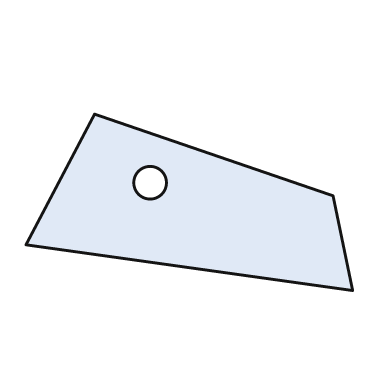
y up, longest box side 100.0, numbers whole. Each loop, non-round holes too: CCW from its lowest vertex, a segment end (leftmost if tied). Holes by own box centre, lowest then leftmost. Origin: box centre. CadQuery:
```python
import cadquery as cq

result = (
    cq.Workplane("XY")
    .moveTo(50.0, -27.0)
    .lineTo(44.0, 2.0)
    .lineTo(-29.0, 27.0)
    .lineTo(-50.0, -13.0)
    .close()
    .moveTo(-12.0, 6.0)
    .circle(5.0)
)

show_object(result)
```